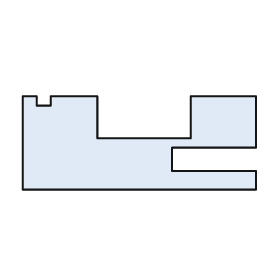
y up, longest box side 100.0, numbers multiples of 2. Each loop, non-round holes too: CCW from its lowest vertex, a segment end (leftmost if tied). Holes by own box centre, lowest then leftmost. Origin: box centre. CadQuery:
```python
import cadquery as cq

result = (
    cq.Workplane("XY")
    .moveTo(-50.0, -20.0)
    .lineTo(50.0, -20.0)
    .lineTo(50.0, -12.0)
    .lineTo(14.0, -12.0)
    .lineTo(14.0, -2.0)
    .lineTo(50.0, -2.0)
    .lineTo(50.0, 20.0)
    .lineTo(22.0, 20.0)
    .lineTo(22.0, 2.0)
    .lineTo(-18.0, 2.0)
    .lineTo(-18.0, 20.0)
    .lineTo(-38.0, 20.0)
    .lineTo(-38.0, 16.0)
    .lineTo(-44.0, 16.0)
    .lineTo(-44.0, 20.0)
    .lineTo(-50.0, 20.0)
    .close()
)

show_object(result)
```